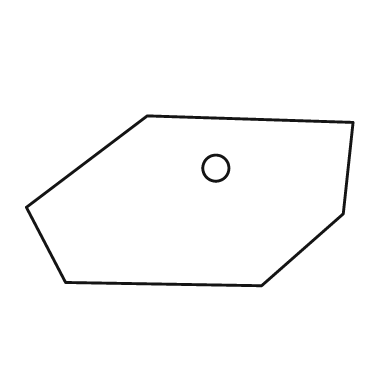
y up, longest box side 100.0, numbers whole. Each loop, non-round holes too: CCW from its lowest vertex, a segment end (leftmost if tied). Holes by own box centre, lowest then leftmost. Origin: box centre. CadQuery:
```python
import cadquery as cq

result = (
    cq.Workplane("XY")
    .moveTo(22.0, -26.0)
    .lineTo(47.0, -4.0)
    .lineTo(50.0, 24.0)
    .lineTo(-13.0, 26.0)
    .lineTo(-50.0, -2.0)
    .lineTo(-38.0, -25.0)
    .close()
    .moveTo(8.0, 10.0)
    .circle(4.0)
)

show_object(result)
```